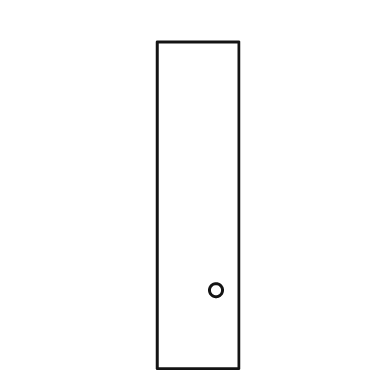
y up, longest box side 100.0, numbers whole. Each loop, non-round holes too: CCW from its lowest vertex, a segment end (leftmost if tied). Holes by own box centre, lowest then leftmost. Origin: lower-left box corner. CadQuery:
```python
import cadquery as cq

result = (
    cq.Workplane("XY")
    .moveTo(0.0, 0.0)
    .lineTo(25.0, 0.0)
    .lineTo(25.0, 100.0)
    .lineTo(0.0, 100.0)
    .close()
    .moveTo(18.0, 24.0)
    .circle(2.0)
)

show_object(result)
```